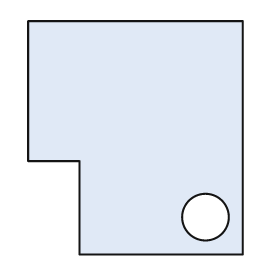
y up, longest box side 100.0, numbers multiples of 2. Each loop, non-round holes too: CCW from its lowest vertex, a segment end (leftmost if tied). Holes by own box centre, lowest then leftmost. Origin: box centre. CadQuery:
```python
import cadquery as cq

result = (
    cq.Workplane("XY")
    .moveTo(-24.0, -50.0)
    .lineTo(46.0, -50.0)
    .lineTo(46.0, 50.0)
    .lineTo(-46.0, 50.0)
    .lineTo(-46.0, -10.0)
    .lineTo(-24.0, -10.0)
    .close()
    .moveTo(30.0, -34.0)
    .circle(10.0)
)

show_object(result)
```